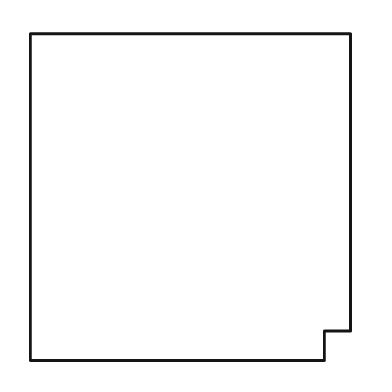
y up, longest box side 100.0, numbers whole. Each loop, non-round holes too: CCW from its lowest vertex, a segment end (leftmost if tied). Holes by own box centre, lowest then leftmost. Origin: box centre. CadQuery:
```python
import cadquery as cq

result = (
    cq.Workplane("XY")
    .moveTo(-49.0, -50.0)
    .lineTo(41.0, -50.0)
    .lineTo(41.0, -41.0)
    .lineTo(49.0, -41.0)
    .lineTo(49.0, 50.0)
    .lineTo(-49.0, 50.0)
    .close()
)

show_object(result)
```